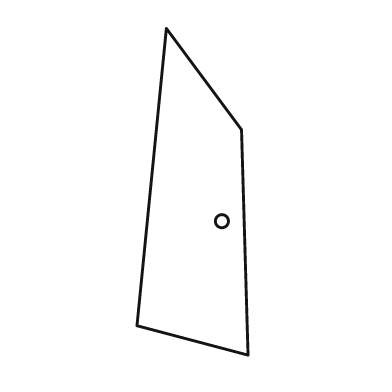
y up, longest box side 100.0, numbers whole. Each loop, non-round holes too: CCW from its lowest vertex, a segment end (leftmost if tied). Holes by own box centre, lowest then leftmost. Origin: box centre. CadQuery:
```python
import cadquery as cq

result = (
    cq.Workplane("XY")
    .moveTo(17.0, -50.0)
    .lineTo(15.0, 19.0)
    .lineTo(-8.0, 50.0)
    .lineTo(-17.0, -41.0)
    .close()
    .moveTo(9.0, -9.0)
    .circle(2.0)
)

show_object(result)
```